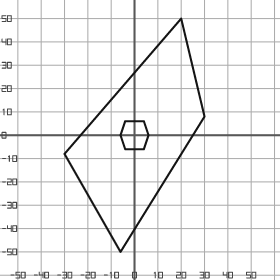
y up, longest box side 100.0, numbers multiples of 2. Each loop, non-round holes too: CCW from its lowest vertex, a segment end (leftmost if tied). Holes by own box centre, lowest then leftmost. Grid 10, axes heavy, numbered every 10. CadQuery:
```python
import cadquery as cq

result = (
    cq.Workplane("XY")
    .moveTo(-6.0, -50.0)
    .lineTo(30.0, 8.0)
    .lineTo(20.0, 50.0)
    .lineTo(-30.0, -8.0)
    .close()
    .moveTo(-4.0, -6.0)
    .lineTo(4.0, -6.0)
    .lineTo(6.0, 0.0)
    .lineTo(4.0, 6.0)
    .lineTo(-4.0, 6.0)
    .lineTo(-6.0, 0.0)
    .close()
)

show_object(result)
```